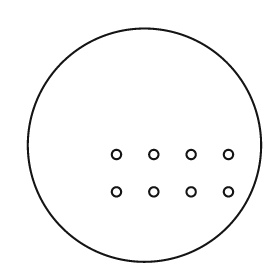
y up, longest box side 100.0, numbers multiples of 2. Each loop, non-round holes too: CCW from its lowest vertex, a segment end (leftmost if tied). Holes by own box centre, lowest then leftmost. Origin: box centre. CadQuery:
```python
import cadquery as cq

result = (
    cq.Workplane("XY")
    .moveTo(0.0, 0.0)
    .circle(50.0)
    .moveTo(-12.0, -20.0)
    .circle(2.0)
    .moveTo(4.0, -20.0)
    .circle(2.0)
    .moveTo(20.0, -20.0)
    .circle(2.0)
    .moveTo(36.0, -20.0)
    .circle(2.0)
    .moveTo(-12.0, -4.0)
    .circle(2.0)
    .moveTo(4.0, -4.0)
    .circle(2.0)
    .moveTo(20.0, -4.0)
    .circle(2.0)
    .moveTo(36.0, -4.0)
    .circle(2.0)
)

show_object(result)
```